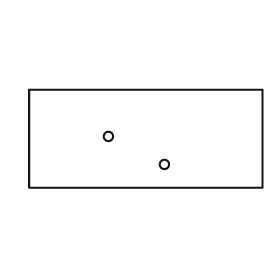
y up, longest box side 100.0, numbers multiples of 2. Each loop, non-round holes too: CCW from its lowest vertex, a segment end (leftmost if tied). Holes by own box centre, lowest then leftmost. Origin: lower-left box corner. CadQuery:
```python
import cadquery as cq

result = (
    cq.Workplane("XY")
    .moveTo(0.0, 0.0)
    .lineTo(100.0, 0.0)
    .lineTo(100.0, 42.0)
    .lineTo(0.0, 42.0)
    .close()
    .moveTo(58.0, 10.0)
    .circle(2.0)
    .moveTo(34.0, 22.0)
    .circle(2.0)
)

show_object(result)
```